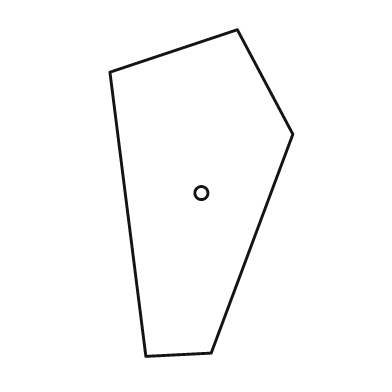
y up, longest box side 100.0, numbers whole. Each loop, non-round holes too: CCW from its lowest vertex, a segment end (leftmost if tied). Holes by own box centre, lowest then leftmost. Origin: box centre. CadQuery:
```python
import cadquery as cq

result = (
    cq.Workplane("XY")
    .moveTo(-17.0, -50.0)
    .lineTo(3.0, -49.0)
    .lineTo(28.0, 18.0)
    .lineTo(11.0, 50.0)
    .lineTo(-28.0, 37.0)
    .close()
    .moveTo(0.0, 0.0)
    .circle(2.0)
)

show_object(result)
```